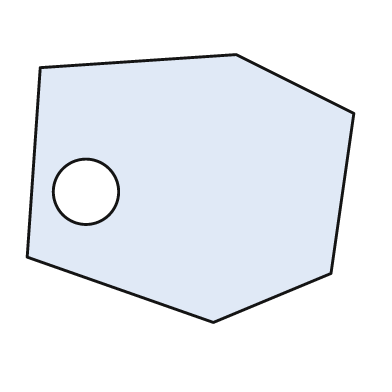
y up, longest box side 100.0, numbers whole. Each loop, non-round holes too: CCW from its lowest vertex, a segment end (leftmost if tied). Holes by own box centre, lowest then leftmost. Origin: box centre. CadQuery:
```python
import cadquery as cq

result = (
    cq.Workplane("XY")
    .moveTo(7.0, -41.0)
    .lineTo(43.0, -26.0)
    .lineTo(50.0, 23.0)
    .lineTo(14.0, 41.0)
    .lineTo(-46.0, 37.0)
    .lineTo(-50.0, -21.0)
    .close()
    .moveTo(-32.0, -1.0)
    .circle(10.0)
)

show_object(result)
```